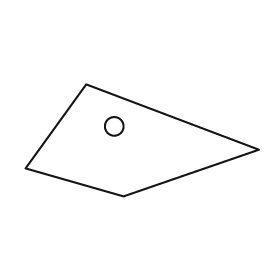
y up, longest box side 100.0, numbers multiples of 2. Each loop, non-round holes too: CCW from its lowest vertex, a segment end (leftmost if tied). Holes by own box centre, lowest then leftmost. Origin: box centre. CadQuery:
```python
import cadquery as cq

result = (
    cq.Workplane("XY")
    .moveTo(-8.0, -24.0)
    .lineTo(50.0, -4.0)
    .lineTo(-24.0, 24.0)
    .lineTo(-50.0, -12.0)
    .close()
    .moveTo(-12.0, 6.0)
    .circle(4.0)
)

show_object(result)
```